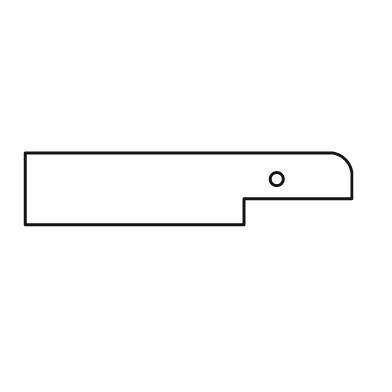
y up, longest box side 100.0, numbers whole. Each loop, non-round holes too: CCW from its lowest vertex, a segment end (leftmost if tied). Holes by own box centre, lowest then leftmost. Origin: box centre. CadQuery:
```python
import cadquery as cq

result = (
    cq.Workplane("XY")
    .moveTo(-50.0, -11.0)
    .lineTo(17.0, -11.0)
    .lineTo(17.0, -3.0)
    .lineTo(50.0, -3.0)
    .lineTo(50.0, 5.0)
    .threePointArc((48.0, 9.0), (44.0, 11.0))
    .lineTo(-50.0, 11.0)
    .close()
    .moveTo(27.0, 3.0)
    .circle(2.0)
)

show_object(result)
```